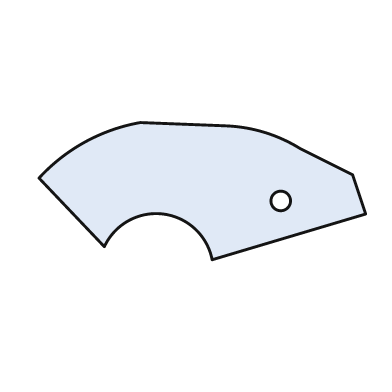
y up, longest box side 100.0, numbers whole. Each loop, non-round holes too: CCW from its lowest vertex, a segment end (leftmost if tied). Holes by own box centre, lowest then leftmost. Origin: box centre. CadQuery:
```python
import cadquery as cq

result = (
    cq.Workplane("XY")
    .moveTo(3.0, -21.0)
    .lineTo(50.0, -7.0)
    .lineTo(46.0, 5.0)
    .lineTo(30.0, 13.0)
    .threePointArc((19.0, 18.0), (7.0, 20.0))
    .lineTo(-19.0, 21.0)
    .threePointArc((-36.0, 15.0), (-50.0, 4.0))
    .lineTo(-30.0, -17.0)
    .threePointArc((-12.0, -7.0), (3.0, -21.0))
    .close()
    .moveTo(24.0, -3.0)
    .circle(3.0)
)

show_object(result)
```